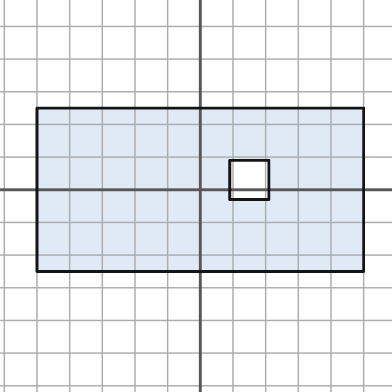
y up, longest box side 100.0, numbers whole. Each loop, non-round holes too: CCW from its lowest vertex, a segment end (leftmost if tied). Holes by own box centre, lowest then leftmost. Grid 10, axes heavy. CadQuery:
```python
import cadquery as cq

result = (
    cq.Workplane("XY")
    .moveTo(-50.0, -25.0)
    .lineTo(50.0, -25.0)
    .lineTo(50.0, 25.0)
    .lineTo(-50.0, 25.0)
    .close()
    .moveTo(9.0, -3.0)
    .lineTo(21.0, -3.0)
    .lineTo(21.0, 9.0)
    .lineTo(9.0, 9.0)
    .close()
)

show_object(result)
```